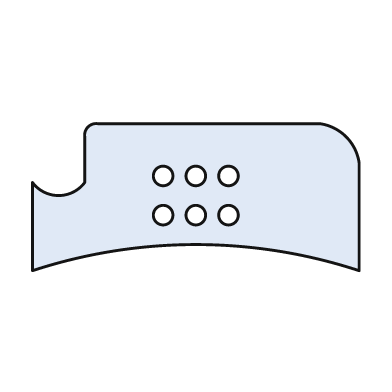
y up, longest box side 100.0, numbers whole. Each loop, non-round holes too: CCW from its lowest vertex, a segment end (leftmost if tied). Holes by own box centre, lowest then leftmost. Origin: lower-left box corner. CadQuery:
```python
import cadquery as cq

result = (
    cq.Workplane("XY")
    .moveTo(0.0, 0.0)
    .threePointArc((50.0, 8.0), (100.0, 0.0))
    .lineTo(100.0, 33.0)
    .threePointArc((96.0, 41.0), (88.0, 45.0))
    .lineTo(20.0, 45.0)
    .threePointArc((17.0, 44.0), (16.0, 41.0))
    .lineTo(16.0, 27.0)
    .threePointArc((8.0, 23.0), (0.0, 27.0))
    .close()
    .moveTo(40.0, 17.0)
    .circle(3.0)
    .moveTo(50.0, 17.0)
    .circle(3.0)
    .moveTo(60.0, 17.0)
    .circle(3.0)
    .moveTo(40.0, 29.0)
    .circle(3.0)
    .moveTo(50.0, 29.0)
    .circle(3.0)
    .moveTo(60.0, 29.0)
    .circle(3.0)
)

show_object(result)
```